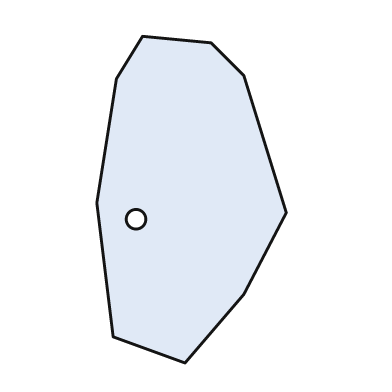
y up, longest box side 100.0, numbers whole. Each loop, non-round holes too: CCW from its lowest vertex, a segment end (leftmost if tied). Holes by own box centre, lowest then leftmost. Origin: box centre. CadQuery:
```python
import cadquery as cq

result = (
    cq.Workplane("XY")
    .moveTo(-2.0, -50.0)
    .lineTo(16.0, -29.0)
    .lineTo(29.0, -4.0)
    .lineTo(16.0, 38.0)
    .lineTo(6.0, 48.0)
    .lineTo(-15.0, 50.0)
    .lineTo(-23.0, 37.0)
    .lineTo(-29.0, -1.0)
    .lineTo(-24.0, -42.0)
    .close()
    .moveTo(-17.0, -6.0)
    .circle(3.0)
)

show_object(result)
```